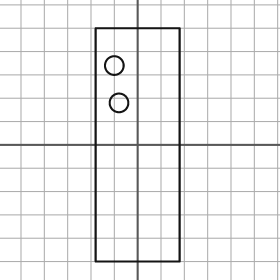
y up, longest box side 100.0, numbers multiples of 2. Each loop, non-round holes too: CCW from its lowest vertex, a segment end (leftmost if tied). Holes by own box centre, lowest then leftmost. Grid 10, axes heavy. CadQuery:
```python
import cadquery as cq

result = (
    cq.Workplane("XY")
    .moveTo(-18.0, -50.0)
    .lineTo(18.0, -50.0)
    .lineTo(18.0, 50.0)
    .lineTo(-18.0, 50.0)
    .close()
    .moveTo(-8.0, 18.0)
    .circle(4.0)
    .moveTo(-10.0, 34.0)
    .circle(4.0)
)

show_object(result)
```